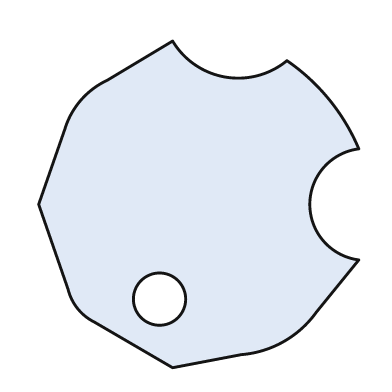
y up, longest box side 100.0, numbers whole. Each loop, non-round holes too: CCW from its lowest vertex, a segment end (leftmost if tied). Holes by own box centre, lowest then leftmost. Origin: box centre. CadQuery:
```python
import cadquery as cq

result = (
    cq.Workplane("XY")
    .moveTo(-8.0, -50.0)
    .lineTo(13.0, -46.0)
    .threePointArc((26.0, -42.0), (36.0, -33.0))
    .lineTo(49.0, -17.0)
    .threePointArc((34.0, 0.0), (49.0, 17.0))
    .threePointArc((40.0, 32.0), (27.0, 44.0))
    .threePointArc((8.0, 39.0), (-8.0, 50.0))
    .lineTo(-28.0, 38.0)
    .threePointArc((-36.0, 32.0), (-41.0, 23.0))
    .lineTo(-49.0, 0.0)
    .lineTo(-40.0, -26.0)
    .threePointArc((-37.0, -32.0), (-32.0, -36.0))
    .close()
    .moveTo(-12.0, -29.0)
    .circle(8.0)
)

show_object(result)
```